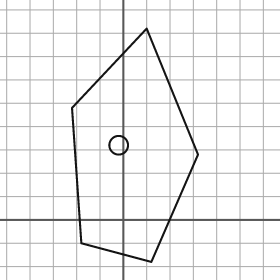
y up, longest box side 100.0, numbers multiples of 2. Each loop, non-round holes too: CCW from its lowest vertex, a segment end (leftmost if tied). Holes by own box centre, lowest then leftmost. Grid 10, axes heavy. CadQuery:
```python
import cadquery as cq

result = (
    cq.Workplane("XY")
    .moveTo(12.0, -18.0)
    .lineTo(32.0, 28.0)
    .lineTo(10.0, 82.0)
    .lineTo(-22.0, 48.0)
    .lineTo(-18.0, -10.0)
    .close()
    .moveTo(-2.0, 32.0)
    .circle(4.0)
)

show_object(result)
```